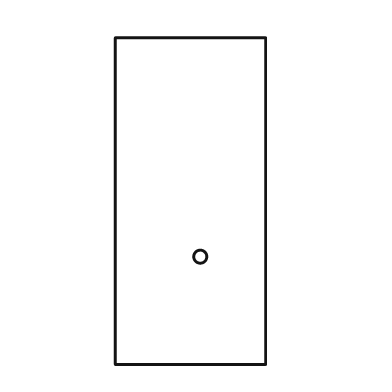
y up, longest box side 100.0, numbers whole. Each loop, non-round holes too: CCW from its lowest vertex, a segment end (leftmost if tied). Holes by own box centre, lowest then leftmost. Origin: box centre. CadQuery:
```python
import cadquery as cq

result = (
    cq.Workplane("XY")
    .moveTo(-23.0, -50.0)
    .lineTo(23.0, -50.0)
    .lineTo(23.0, 50.0)
    .lineTo(-23.0, 50.0)
    .close()
    .moveTo(3.0, -17.0)
    .circle(2.0)
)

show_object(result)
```